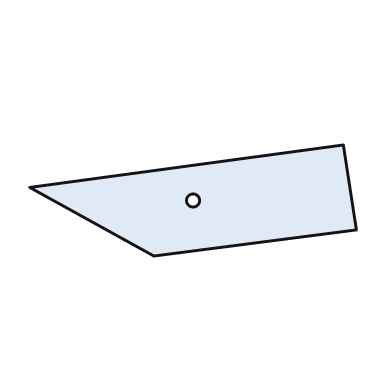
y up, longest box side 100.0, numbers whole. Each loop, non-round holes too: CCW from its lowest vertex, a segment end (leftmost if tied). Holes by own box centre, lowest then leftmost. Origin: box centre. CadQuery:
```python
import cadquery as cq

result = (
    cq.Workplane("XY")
    .moveTo(-12.0, -17.0)
    .lineTo(50.0, -9.0)
    .lineTo(46.0, 17.0)
    .lineTo(-50.0, 4.0)
    .close()
    .moveTo(0.0, 0.0)
    .circle(2.0)
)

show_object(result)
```